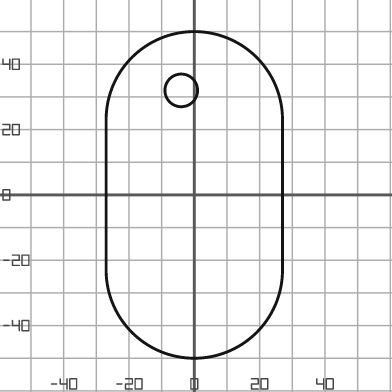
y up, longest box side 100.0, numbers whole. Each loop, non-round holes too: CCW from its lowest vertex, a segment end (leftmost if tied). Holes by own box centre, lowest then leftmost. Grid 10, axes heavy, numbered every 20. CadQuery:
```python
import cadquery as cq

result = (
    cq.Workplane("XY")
    .moveTo(-27.0, -23.0)
    .threePointArc((0.0, -50.0), (27.0, -23.0))
    .lineTo(27.0, 23.0)
    .threePointArc((0.0, 50.0), (-27.0, 23.0))
    .close()
    .moveTo(-4.0, 32.0)
    .circle(5.0)
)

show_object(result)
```